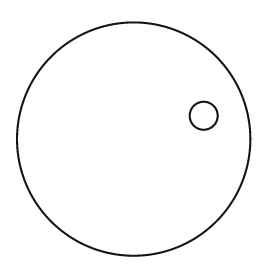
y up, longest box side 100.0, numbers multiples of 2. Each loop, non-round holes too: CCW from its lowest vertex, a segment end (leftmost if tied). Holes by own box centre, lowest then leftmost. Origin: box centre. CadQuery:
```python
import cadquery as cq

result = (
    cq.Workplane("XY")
    .moveTo(0.0, 0.0)
    .circle(50.0)
    .moveTo(30.0, 10.0)
    .circle(6.0)
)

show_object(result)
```